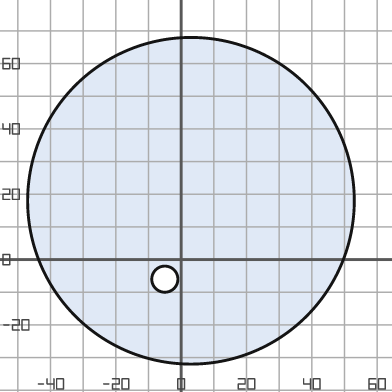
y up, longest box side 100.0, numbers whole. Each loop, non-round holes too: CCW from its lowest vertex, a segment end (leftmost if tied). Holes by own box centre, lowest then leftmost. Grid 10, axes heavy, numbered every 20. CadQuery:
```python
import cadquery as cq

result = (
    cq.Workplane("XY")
    .moveTo(3.0, 18.0)
    .circle(50.0)
    .moveTo(-5.0, -6.0)
    .circle(4.0)
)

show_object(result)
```